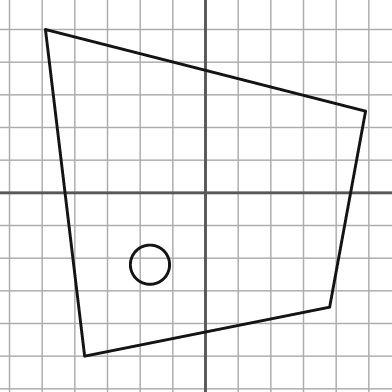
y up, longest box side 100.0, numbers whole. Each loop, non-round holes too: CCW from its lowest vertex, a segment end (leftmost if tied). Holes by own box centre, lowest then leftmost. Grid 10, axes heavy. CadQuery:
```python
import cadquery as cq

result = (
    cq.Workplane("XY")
    .moveTo(-37.0, -50.0)
    .lineTo(38.0, -35.0)
    .lineTo(49.0, 25.0)
    .lineTo(-49.0, 50.0)
    .close()
    .moveTo(-17.0, -22.0)
    .circle(6.0)
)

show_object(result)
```